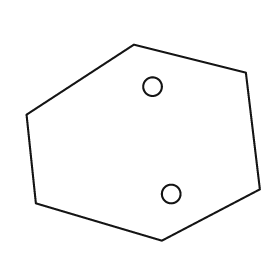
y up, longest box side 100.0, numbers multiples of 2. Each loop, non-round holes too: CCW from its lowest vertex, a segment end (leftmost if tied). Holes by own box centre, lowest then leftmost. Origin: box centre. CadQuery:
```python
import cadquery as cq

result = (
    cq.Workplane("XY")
    .moveTo(8.0, -42.0)
    .lineTo(50.0, -20.0)
    .lineTo(44.0, 30.0)
    .lineTo(-4.0, 42.0)
    .lineTo(-50.0, 12.0)
    .lineTo(-46.0, -26.0)
    .close()
    .moveTo(12.0, -22.0)
    .circle(4.0)
    .moveTo(4.0, 24.0)
    .circle(4.0)
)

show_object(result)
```